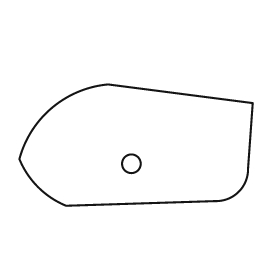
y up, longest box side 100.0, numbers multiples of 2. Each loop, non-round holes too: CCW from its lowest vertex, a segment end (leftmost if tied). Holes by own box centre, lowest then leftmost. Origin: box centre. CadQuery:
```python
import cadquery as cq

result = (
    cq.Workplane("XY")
    .moveTo(-30.0, -26.0)
    .lineTo(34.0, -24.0)
    .threePointArc((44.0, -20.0), (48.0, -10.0))
    .lineTo(50.0, 18.0)
    .lineTo(-12.0, 26.0)
    .threePointArc((-36.0, 16.0), (-50.0, -6.0))
    .threePointArc((-42.0, -18.0), (-30.0, -26.0))
    .close()
    .moveTo(-2.0, -8.0)
    .circle(4.0)
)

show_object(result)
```